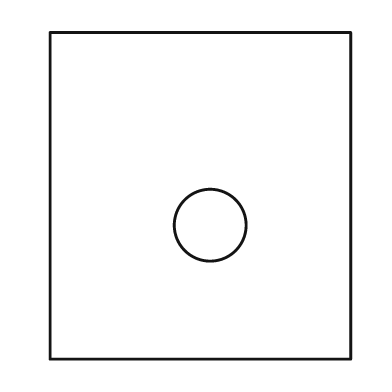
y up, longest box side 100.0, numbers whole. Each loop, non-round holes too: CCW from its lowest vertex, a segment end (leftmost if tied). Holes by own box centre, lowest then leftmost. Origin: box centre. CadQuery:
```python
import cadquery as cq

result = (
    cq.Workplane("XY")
    .moveTo(-46.0, -50.0)
    .lineTo(46.0, -50.0)
    .lineTo(46.0, 50.0)
    .lineTo(-46.0, 50.0)
    .close()
    .moveTo(3.0, -9.0)
    .circle(11.0)
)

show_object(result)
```